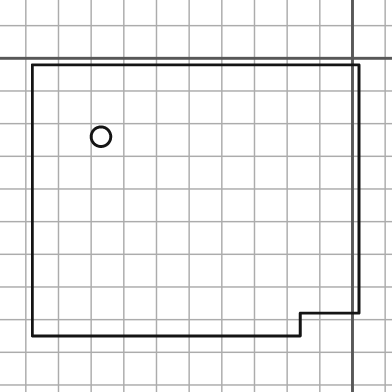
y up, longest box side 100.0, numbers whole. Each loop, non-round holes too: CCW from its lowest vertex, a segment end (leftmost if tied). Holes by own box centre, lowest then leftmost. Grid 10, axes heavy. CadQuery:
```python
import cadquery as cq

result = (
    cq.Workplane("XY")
    .moveTo(-98.0, -85.0)
    .lineTo(-16.0, -85.0)
    .lineTo(-16.0, -78.0)
    .lineTo(2.0, -78.0)
    .lineTo(2.0, -2.0)
    .lineTo(-98.0, -2.0)
    .close()
    .moveTo(-77.0, -24.0)
    .circle(3.0)
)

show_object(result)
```